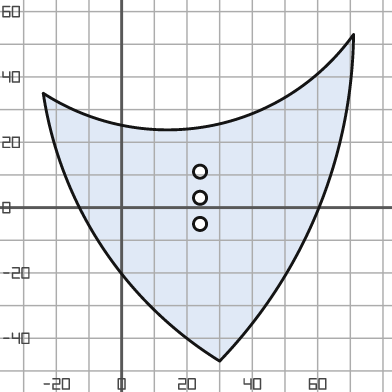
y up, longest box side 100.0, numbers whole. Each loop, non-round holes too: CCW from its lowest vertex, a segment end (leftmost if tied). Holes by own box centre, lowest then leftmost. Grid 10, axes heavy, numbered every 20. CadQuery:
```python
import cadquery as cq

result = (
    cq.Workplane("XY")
    .moveTo(30.0, -47.0)
    .threePointArc((60.0, -1.0), (71.0, 53.0))
    .threePointArc((27.0, 25.0), (-24.0, 35.0))
    .threePointArc((-6.0, -12.0), (30.0, -47.0))
    .close()
    .moveTo(24.0, -5.0)
    .circle(2.0)
    .moveTo(24.0, 3.0)
    .circle(2.0)
    .moveTo(24.0, 11.0)
    .circle(2.0)
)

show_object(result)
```